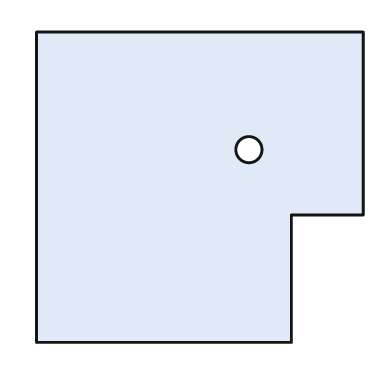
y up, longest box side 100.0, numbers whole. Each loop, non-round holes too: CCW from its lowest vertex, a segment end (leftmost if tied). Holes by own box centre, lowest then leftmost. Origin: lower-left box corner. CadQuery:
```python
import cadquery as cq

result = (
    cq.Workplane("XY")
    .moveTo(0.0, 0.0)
    .lineTo(78.0, 0.0)
    .lineTo(78.0, 39.0)
    .lineTo(100.0, 39.0)
    .lineTo(100.0, 95.0)
    .lineTo(0.0, 95.0)
    .close()
    .moveTo(65.0, 59.0)
    .circle(4.0)
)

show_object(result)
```